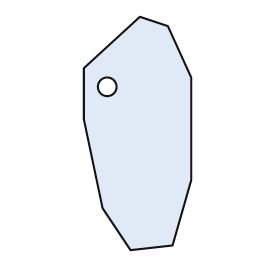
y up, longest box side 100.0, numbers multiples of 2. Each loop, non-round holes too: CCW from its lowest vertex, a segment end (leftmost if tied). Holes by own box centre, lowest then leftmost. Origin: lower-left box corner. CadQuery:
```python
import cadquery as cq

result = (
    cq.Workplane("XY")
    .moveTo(20.0, 0.0)
    .lineTo(38.0, 2.0)
    .lineTo(46.0, 30.0)
    .lineTo(46.0, 74.0)
    .lineTo(36.0, 96.0)
    .lineTo(24.0, 100.0)
    .lineTo(0.0, 78.0)
    .lineTo(0.0, 56.0)
    .lineTo(8.0, 18.0)
    .close()
    .moveTo(10.0, 70.0)
    .circle(4.0)
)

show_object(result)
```